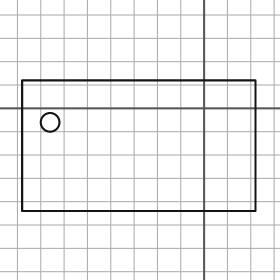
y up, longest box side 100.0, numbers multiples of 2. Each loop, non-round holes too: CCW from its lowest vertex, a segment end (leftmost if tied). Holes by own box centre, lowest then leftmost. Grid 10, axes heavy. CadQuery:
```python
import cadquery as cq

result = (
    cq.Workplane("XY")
    .moveTo(-78.0, -44.0)
    .lineTo(22.0, -44.0)
    .lineTo(22.0, 12.0)
    .lineTo(-78.0, 12.0)
    .close()
    .moveTo(-66.0, -6.0)
    .circle(4.0)
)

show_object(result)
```